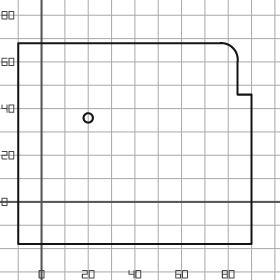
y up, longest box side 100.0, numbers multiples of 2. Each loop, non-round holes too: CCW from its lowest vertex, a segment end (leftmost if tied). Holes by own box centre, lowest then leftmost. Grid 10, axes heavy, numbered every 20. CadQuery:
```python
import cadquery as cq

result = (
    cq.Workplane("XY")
    .moveTo(-10.0, -18.0)
    .lineTo(90.0, -18.0)
    .lineTo(90.0, 46.0)
    .lineTo(84.0, 46.0)
    .lineTo(84.0, 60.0)
    .threePointArc((82.0, 66.0), (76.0, 68.0))
    .lineTo(-10.0, 68.0)
    .close()
    .moveTo(20.0, 36.0)
    .circle(2.0)
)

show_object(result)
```